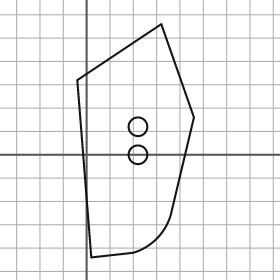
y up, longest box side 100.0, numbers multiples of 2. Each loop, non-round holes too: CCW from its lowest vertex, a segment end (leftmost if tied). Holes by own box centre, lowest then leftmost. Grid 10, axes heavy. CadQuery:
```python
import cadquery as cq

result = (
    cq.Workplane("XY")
    .moveTo(2.0, -44.0)
    .lineTo(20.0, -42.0)
    .threePointArc((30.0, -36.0), (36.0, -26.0))
    .lineTo(46.0, 16.0)
    .lineTo(32.0, 56.0)
    .lineTo(-4.0, 32.0)
    .close()
    .moveTo(22.0, 0.0)
    .circle(4.0)
    .moveTo(22.0, 12.0)
    .circle(4.0)
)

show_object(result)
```